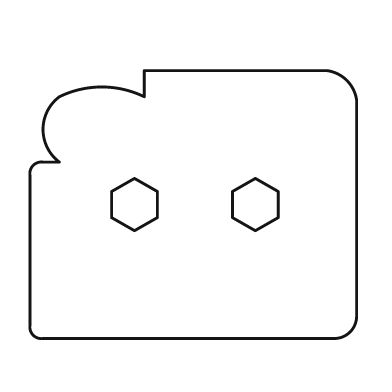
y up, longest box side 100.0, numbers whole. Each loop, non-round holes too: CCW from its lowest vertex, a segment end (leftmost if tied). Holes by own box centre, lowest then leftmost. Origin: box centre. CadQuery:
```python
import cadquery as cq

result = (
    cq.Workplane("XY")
    .moveTo(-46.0, -41.0)
    .lineTo(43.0, -41.0)
    .threePointArc((48.0, -39.0), (50.0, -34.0))
    .lineTo(50.0, 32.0)
    .threePointArc((47.0, 38.0), (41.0, 41.0))
    .lineTo(-15.0, 41.0)
    .lineTo(-15.0, 33.0)
    .threePointArc((-28.0, 36.0), (-41.0, 33.0))
    .threePointArc((-46.0, 23.0), (-41.0, 13.0))
    .lineTo(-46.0, 13.0)
    .threePointArc((-49.0, 12.0), (-50.0, 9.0))
    .lineTo(-50.0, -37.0)
    .threePointArc((-49.0, -40.0), (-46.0, -41.0))
    .close()
    .moveTo(-18.0, -8.0)
    .lineTo(-11.0, -4.0)
    .lineTo(-11.0, 4.0)
    .lineTo(-18.0, 8.0)
    .lineTo(-25.0, 4.0)
    .lineTo(-25.0, -4.0)
    .close()
    .moveTo(19.0, -8.0)
    .lineTo(26.0, -4.0)
    .lineTo(26.0, 4.0)
    .lineTo(19.0, 8.0)
    .lineTo(12.0, 4.0)
    .lineTo(12.0, -4.0)
    .close()
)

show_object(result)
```